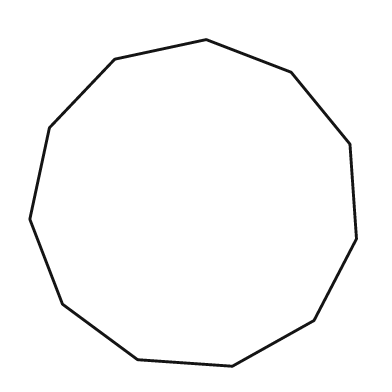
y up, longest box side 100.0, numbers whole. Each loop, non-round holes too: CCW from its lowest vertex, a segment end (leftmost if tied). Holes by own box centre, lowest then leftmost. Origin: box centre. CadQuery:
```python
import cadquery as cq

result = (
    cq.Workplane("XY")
    .moveTo(12.0, -50.0)
    .lineTo(37.0, -36.0)
    .lineTo(50.0, -11.0)
    .lineTo(48.0, 18.0)
    .lineTo(30.0, 40.0)
    .lineTo(4.0, 50.0)
    .lineTo(-24.0, 44.0)
    .lineTo(-44.0, 23.0)
    .lineTo(-50.0, -5.0)
    .lineTo(-40.0, -31.0)
    .lineTo(-17.0, -48.0)
    .close()
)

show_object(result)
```